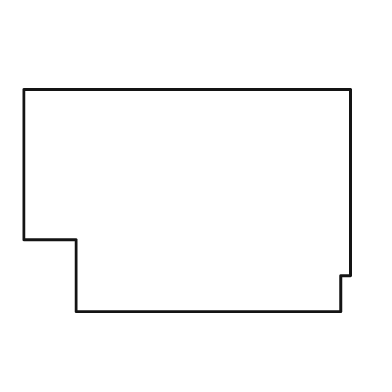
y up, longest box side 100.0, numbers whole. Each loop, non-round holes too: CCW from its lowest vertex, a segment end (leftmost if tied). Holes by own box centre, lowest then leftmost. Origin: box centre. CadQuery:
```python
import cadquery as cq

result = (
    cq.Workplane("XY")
    .moveTo(-34.0, -34.0)
    .lineTo(47.0, -34.0)
    .lineTo(47.0, -23.0)
    .lineTo(50.0, -23.0)
    .lineTo(50.0, 34.0)
    .lineTo(-50.0, 34.0)
    .lineTo(-50.0, -12.0)
    .lineTo(-34.0, -12.0)
    .close()
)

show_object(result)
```